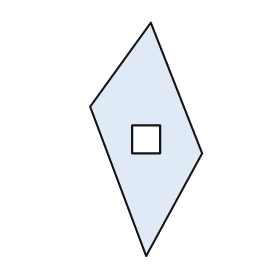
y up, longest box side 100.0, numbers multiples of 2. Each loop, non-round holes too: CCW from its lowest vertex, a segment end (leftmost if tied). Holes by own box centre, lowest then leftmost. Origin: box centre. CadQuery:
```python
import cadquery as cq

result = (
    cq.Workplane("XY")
    .moveTo(0.0, -50.0)
    .lineTo(24.0, -6.0)
    .lineTo(2.0, 50.0)
    .lineTo(-24.0, 14.0)
    .close()
    .moveTo(-6.0, -6.0)
    .lineTo(6.0, -6.0)
    .lineTo(6.0, 6.0)
    .lineTo(-6.0, 6.0)
    .close()
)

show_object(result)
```